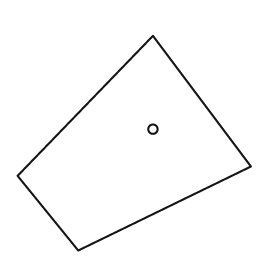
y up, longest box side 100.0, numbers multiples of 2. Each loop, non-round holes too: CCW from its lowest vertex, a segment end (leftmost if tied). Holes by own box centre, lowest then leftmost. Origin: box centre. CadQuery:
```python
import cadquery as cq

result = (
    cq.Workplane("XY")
    .moveTo(-24.0, -46.0)
    .lineTo(50.0, -10.0)
    .lineTo(8.0, 46.0)
    .lineTo(-50.0, -14.0)
    .close()
    .moveTo(8.0, 6.0)
    .circle(2.0)
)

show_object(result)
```